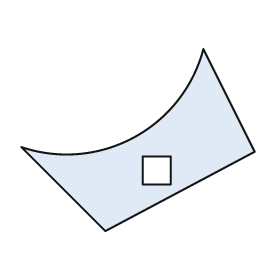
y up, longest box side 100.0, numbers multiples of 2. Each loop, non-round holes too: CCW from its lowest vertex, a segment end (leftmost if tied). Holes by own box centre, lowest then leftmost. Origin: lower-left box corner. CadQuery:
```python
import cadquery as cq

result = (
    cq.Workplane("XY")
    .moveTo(36.0, 0.0)
    .lineTo(100.0, 34.0)
    .lineTo(78.0, 78.0)
    .threePointArc((48.0, 40.0), (0.0, 36.0))
    .close()
    .moveTo(52.0, 20.0)
    .lineTo(64.0, 20.0)
    .lineTo(64.0, 32.0)
    .lineTo(52.0, 32.0)
    .close()
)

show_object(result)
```